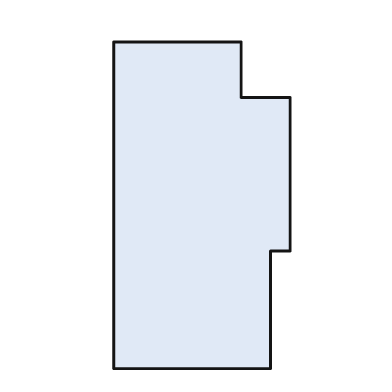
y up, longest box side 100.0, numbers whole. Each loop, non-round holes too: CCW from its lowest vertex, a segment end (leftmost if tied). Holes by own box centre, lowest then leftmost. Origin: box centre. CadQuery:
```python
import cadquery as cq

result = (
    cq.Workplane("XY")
    .moveTo(-27.0, -50.0)
    .lineTo(21.0, -50.0)
    .lineTo(21.0, -14.0)
    .lineTo(27.0, -14.0)
    .lineTo(27.0, 33.0)
    .lineTo(12.0, 33.0)
    .lineTo(12.0, 50.0)
    .lineTo(-27.0, 50.0)
    .close()
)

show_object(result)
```